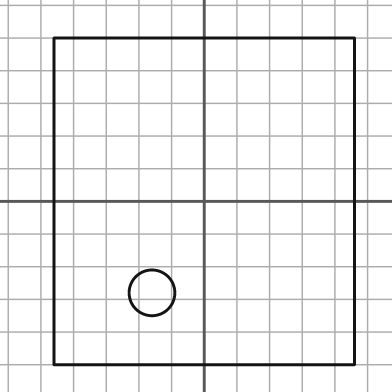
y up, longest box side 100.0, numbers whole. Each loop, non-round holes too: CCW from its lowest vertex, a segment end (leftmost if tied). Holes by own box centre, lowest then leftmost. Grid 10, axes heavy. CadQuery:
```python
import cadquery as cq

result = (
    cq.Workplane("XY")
    .moveTo(-46.0, -50.0)
    .lineTo(46.0, -50.0)
    .lineTo(46.0, 50.0)
    .lineTo(-46.0, 50.0)
    .close()
    .moveTo(-16.0, -28.0)
    .circle(7.0)
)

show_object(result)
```